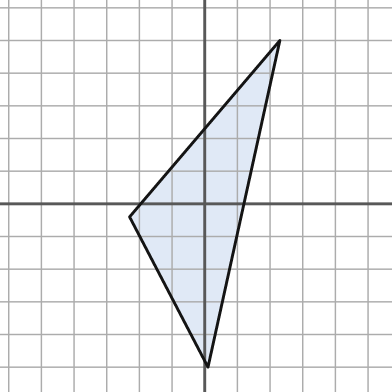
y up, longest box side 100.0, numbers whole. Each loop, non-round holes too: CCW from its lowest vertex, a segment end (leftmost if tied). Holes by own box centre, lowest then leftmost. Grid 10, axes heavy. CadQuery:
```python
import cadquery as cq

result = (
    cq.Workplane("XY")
    .moveTo(1.0, -50.0)
    .lineTo(23.0, 50.0)
    .lineTo(-23.0, -4.0)
    .close()
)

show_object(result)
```